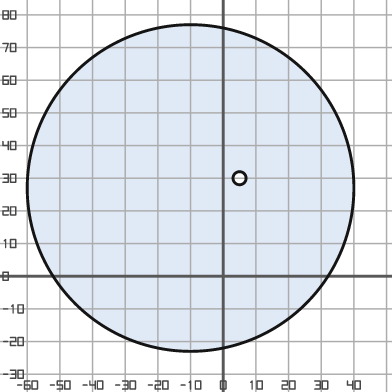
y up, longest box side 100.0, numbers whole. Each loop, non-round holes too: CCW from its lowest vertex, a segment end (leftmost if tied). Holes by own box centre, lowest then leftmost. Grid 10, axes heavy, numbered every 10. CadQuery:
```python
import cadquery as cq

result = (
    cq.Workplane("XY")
    .moveTo(-10.0, 27.0)
    .circle(50.0)
    .moveTo(5.0, 30.0)
    .circle(2.0)
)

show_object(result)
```